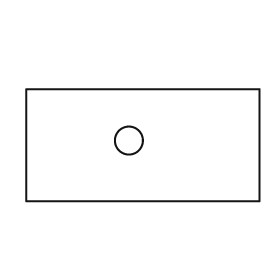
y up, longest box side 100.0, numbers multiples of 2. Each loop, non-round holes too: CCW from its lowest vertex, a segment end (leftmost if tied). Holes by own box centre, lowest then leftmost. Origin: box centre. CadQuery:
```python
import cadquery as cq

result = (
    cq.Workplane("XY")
    .moveTo(-50.0, -24.0)
    .lineTo(50.0, -24.0)
    .lineTo(50.0, 24.0)
    .lineTo(-50.0, 24.0)
    .close()
    .moveTo(-6.0, 2.0)
    .circle(6.0)
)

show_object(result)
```